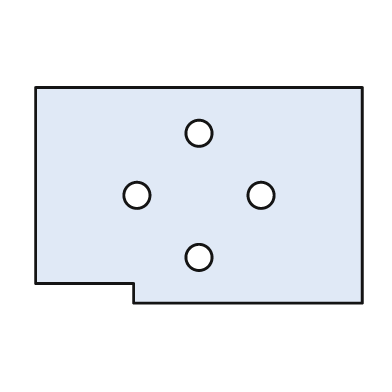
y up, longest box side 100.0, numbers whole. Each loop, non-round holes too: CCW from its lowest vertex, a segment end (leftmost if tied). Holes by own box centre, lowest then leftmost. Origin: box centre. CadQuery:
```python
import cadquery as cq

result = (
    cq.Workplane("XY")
    .moveTo(-20.0, -33.0)
    .lineTo(50.0, -33.0)
    .lineTo(50.0, 33.0)
    .lineTo(-50.0, 33.0)
    .lineTo(-50.0, -27.0)
    .lineTo(-20.0, -27.0)
    .close()
    .moveTo(0.0, -19.0)
    .circle(4.0)
    .moveTo(-19.0, 0.0)
    .circle(4.0)
    .moveTo(19.0, 0.0)
    .circle(4.0)
    .moveTo(0.0, 19.0)
    .circle(4.0)
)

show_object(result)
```